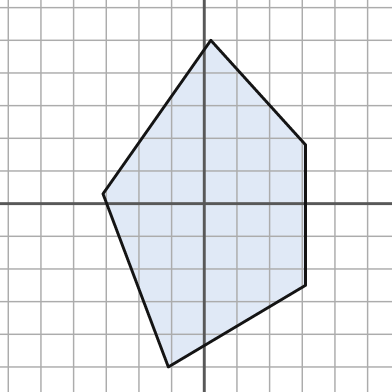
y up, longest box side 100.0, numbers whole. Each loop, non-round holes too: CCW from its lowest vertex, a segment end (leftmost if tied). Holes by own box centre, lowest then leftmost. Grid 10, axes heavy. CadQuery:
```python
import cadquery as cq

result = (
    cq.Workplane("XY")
    .moveTo(-11.0, -50.0)
    .lineTo(31.0, -25.0)
    .lineTo(31.0, 18.0)
    .lineTo(2.0, 50.0)
    .lineTo(-31.0, 3.0)
    .close()
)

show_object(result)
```